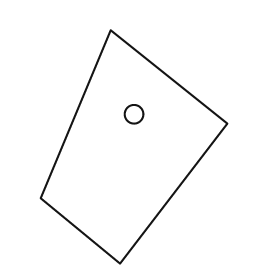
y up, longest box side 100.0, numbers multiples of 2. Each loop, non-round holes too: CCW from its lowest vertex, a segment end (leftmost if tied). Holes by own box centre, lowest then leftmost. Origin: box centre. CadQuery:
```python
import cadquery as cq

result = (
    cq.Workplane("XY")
    .moveTo(-6.0, -50.0)
    .lineTo(40.0, 10.0)
    .lineTo(-10.0, 50.0)
    .lineTo(-40.0, -22.0)
    .close()
    .moveTo(0.0, 14.0)
    .circle(4.0)
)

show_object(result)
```